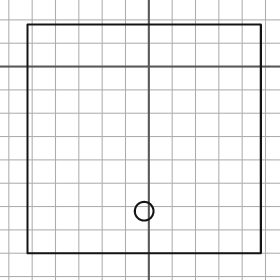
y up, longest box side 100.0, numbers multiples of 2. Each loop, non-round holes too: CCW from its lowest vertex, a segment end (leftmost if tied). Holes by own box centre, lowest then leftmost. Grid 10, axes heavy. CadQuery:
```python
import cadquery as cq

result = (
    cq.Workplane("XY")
    .moveTo(-52.0, -80.0)
    .lineTo(48.0, -80.0)
    .lineTo(48.0, 18.0)
    .lineTo(-52.0, 18.0)
    .close()
    .moveTo(-2.0, -62.0)
    .circle(4.0)
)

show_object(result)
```